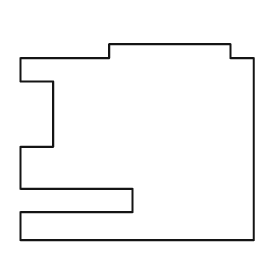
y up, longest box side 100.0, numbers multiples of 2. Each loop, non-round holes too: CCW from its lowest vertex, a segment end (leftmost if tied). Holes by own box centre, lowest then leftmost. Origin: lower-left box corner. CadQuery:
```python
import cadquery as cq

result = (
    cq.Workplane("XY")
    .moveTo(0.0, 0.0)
    .lineTo(100.0, 0.0)
    .lineTo(100.0, 78.0)
    .lineTo(90.0, 78.0)
    .lineTo(90.0, 84.0)
    .lineTo(38.0, 84.0)
    .lineTo(38.0, 78.0)
    .lineTo(0.0, 78.0)
    .lineTo(0.0, 68.0)
    .lineTo(14.0, 68.0)
    .lineTo(14.0, 40.0)
    .lineTo(0.0, 40.0)
    .lineTo(0.0, 22.0)
    .lineTo(48.0, 22.0)
    .lineTo(48.0, 12.0)
    .lineTo(0.0, 12.0)
    .close()
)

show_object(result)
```